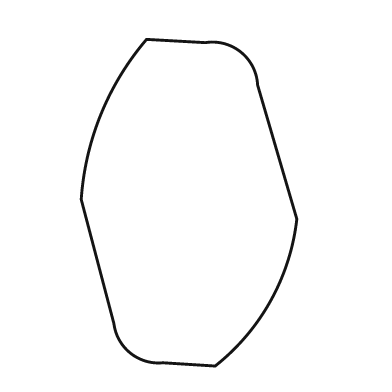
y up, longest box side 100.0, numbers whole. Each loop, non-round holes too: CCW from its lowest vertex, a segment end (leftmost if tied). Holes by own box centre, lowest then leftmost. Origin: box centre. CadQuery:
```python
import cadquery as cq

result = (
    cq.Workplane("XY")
    .moveTo(8.0, -50.0)
    .threePointArc((25.0, -30.0), (33.0, -5.0))
    .lineTo(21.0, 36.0)
    .threePointArc((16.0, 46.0), (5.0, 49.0))
    .lineTo(-13.0, 50.0)
    .threePointArc((-27.0, 27.0), (-33.0, 1.0))
    .lineTo(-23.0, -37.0)
    .threePointArc((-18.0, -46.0), (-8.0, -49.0))
    .close()
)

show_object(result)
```